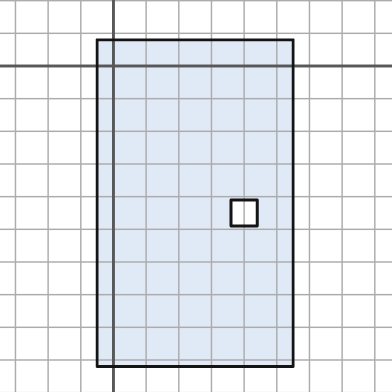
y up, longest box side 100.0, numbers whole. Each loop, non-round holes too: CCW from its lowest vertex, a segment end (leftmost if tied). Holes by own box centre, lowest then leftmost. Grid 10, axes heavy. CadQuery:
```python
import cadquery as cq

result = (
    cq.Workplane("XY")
    .moveTo(-5.0, -92.0)
    .lineTo(55.0, -92.0)
    .lineTo(55.0, 8.0)
    .lineTo(-5.0, 8.0)
    .close()
    .moveTo(36.0, -49.0)
    .lineTo(44.0, -49.0)
    .lineTo(44.0, -41.0)
    .lineTo(36.0, -41.0)
    .close()
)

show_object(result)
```